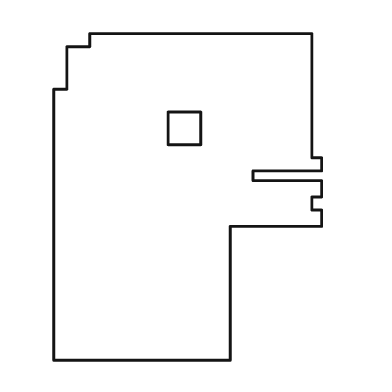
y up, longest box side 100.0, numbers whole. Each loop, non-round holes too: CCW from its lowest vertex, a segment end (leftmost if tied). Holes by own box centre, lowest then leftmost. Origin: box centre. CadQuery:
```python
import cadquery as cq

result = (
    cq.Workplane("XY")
    .moveTo(-41.0, -50.0)
    .lineTo(13.0, -50.0)
    .lineTo(13.0, -9.0)
    .lineTo(41.0, -9.0)
    .lineTo(41.0, -4.0)
    .lineTo(38.0, -4.0)
    .lineTo(38.0, 0.0)
    .lineTo(41.0, 0.0)
    .lineTo(41.0, 5.0)
    .lineTo(20.0, 5.0)
    .lineTo(20.0, 8.0)
    .lineTo(41.0, 8.0)
    .lineTo(41.0, 12.0)
    .lineTo(38.0, 12.0)
    .lineTo(38.0, 50.0)
    .lineTo(-30.0, 50.0)
    .lineTo(-30.0, 46.0)
    .lineTo(-37.0, 46.0)
    .lineTo(-37.0, 33.0)
    .lineTo(-41.0, 33.0)
    .close()
    .moveTo(-6.0, 16.0)
    .lineTo(4.0, 16.0)
    .lineTo(4.0, 26.0)
    .lineTo(-6.0, 26.0)
    .close()
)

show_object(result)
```